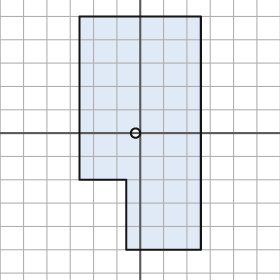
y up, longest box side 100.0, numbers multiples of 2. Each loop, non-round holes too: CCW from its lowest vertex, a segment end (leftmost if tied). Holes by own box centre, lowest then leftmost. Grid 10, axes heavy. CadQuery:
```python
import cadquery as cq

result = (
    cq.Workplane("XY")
    .moveTo(-6.0, -50.0)
    .lineTo(26.0, -50.0)
    .lineTo(26.0, 50.0)
    .lineTo(-26.0, 50.0)
    .lineTo(-26.0, -20.0)
    .lineTo(-6.0, -20.0)
    .close()
    .moveTo(-2.0, 0.0)
    .circle(2.0)
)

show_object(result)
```